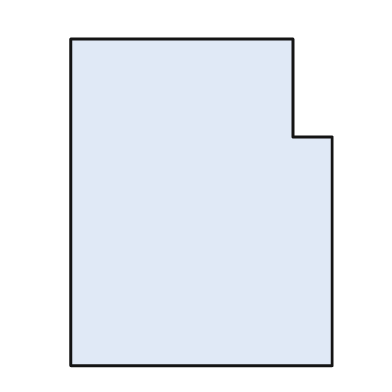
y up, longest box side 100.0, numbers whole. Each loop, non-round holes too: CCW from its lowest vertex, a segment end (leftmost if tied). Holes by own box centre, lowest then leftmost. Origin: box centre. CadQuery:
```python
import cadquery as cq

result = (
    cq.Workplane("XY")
    .moveTo(-40.0, -50.0)
    .lineTo(40.0, -50.0)
    .lineTo(40.0, 20.0)
    .lineTo(28.0, 20.0)
    .lineTo(28.0, 50.0)
    .lineTo(-40.0, 50.0)
    .close()
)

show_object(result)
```